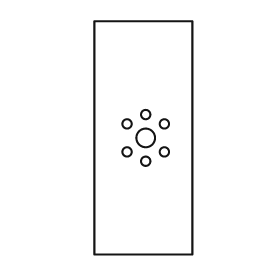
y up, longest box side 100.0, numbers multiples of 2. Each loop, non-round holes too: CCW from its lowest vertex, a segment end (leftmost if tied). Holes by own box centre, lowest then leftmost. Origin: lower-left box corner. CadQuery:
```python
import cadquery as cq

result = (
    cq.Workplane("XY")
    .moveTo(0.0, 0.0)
    .lineTo(42.0, 0.0)
    .lineTo(42.0, 100.0)
    .lineTo(0.0, 100.0)
    .close()
    .moveTo(22.0, 40.0)
    .circle(2.0)
    .moveTo(14.0, 44.0)
    .circle(2.0)
    .moveTo(30.0, 44.0)
    .circle(2.0)
    .moveTo(22.0, 50.0)
    .circle(4.0)
    .moveTo(14.0, 56.0)
    .circle(2.0)
    .moveTo(30.0, 56.0)
    .circle(2.0)
    .moveTo(22.0, 60.0)
    .circle(2.0)
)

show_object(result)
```